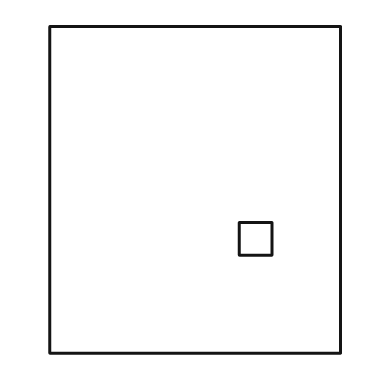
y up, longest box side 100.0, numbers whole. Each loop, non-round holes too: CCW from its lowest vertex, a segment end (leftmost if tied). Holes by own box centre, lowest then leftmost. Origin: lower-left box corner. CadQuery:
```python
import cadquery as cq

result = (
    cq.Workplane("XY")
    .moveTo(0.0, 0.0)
    .lineTo(89.0, 0.0)
    .lineTo(89.0, 100.0)
    .lineTo(0.0, 100.0)
    .close()
    .moveTo(58.0, 30.0)
    .lineTo(68.0, 30.0)
    .lineTo(68.0, 40.0)
    .lineTo(58.0, 40.0)
    .close()
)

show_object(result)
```